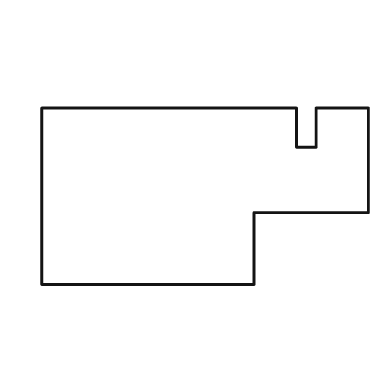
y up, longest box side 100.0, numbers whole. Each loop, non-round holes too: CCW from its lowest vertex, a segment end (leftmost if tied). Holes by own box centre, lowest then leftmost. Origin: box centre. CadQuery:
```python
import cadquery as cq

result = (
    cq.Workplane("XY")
    .moveTo(-50.0, -27.0)
    .lineTo(15.0, -27.0)
    .lineTo(15.0, -5.0)
    .lineTo(50.0, -5.0)
    .lineTo(50.0, 27.0)
    .lineTo(34.0, 27.0)
    .lineTo(34.0, 15.0)
    .lineTo(28.0, 15.0)
    .lineTo(28.0, 27.0)
    .lineTo(-50.0, 27.0)
    .close()
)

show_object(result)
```